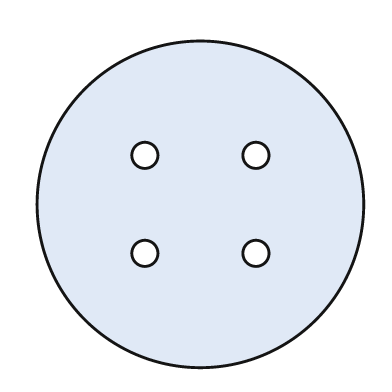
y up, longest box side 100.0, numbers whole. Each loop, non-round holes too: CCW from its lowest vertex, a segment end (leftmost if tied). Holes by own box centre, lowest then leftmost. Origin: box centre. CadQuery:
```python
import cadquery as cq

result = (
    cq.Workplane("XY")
    .moveTo(0.0, 0.0)
    .circle(50.0)
    .moveTo(-17.0, -15.0)
    .circle(4.0)
    .moveTo(17.0, -15.0)
    .circle(4.0)
    .moveTo(-17.0, 15.0)
    .circle(4.0)
    .moveTo(17.0, 15.0)
    .circle(4.0)
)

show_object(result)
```